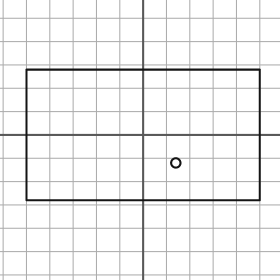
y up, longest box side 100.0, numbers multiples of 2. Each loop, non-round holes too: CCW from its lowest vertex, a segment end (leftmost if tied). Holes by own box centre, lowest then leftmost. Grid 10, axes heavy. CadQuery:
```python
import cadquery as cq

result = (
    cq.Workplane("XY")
    .moveTo(-50.0, -28.0)
    .lineTo(50.0, -28.0)
    .lineTo(50.0, 28.0)
    .lineTo(-50.0, 28.0)
    .close()
    .moveTo(14.0, -12.0)
    .circle(2.0)
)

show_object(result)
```